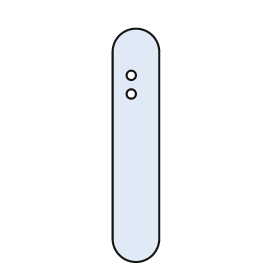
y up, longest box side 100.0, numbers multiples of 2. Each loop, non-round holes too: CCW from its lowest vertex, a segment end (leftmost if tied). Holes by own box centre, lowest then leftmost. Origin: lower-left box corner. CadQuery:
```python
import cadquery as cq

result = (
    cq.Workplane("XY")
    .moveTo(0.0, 10.0)
    .threePointArc((10.0, 0.0), (20.0, 10.0))
    .lineTo(20.0, 90.0)
    .threePointArc((10.0, 100.0), (0.0, 90.0))
    .close()
    .moveTo(8.0, 72.0)
    .circle(2.0)
    .moveTo(8.0, 80.0)
    .circle(2.0)
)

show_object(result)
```